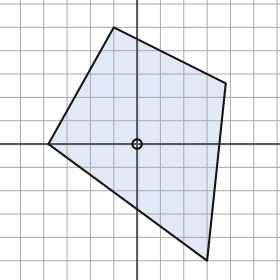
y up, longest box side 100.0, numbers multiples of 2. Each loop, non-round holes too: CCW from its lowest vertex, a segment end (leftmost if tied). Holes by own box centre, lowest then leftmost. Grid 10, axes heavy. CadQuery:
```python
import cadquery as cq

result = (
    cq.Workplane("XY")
    .moveTo(30.0, -50.0)
    .lineTo(38.0, 26.0)
    .lineTo(-10.0, 50.0)
    .lineTo(-38.0, 0.0)
    .close()
    .moveTo(0.0, 0.0)
    .circle(2.0)
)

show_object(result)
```